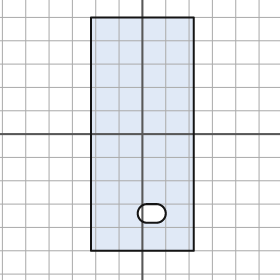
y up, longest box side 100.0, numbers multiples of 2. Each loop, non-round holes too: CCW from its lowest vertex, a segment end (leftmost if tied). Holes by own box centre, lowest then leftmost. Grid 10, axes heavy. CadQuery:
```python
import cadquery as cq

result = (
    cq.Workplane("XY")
    .moveTo(-22.0, -50.0)
    .lineTo(22.0, -50.0)
    .lineTo(22.0, 50.0)
    .lineTo(-22.0, 50.0)
    .close()
    .moveTo(2.0, -38.0)
    .lineTo(6.0, -38.0)
    .threePointArc((10.0, -34.0), (6.0, -30.0))
    .lineTo(2.0, -30.0)
    .threePointArc((-2.0, -34.0), (2.0, -38.0))
    .close()
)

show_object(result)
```